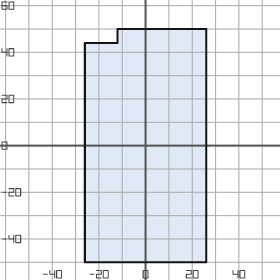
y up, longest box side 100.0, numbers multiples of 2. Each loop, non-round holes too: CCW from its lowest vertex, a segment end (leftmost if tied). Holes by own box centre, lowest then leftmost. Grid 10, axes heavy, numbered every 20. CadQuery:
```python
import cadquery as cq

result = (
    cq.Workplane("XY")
    .moveTo(-26.0, -50.0)
    .lineTo(26.0, -50.0)
    .lineTo(26.0, 50.0)
    .lineTo(-12.0, 50.0)
    .lineTo(-12.0, 44.0)
    .lineTo(-26.0, 44.0)
    .close()
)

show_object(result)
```